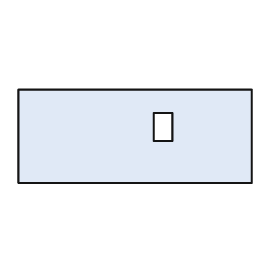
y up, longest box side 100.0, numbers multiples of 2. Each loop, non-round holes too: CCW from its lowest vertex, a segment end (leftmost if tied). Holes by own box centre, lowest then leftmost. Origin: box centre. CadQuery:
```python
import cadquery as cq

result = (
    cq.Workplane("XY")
    .moveTo(-50.0, -20.0)
    .lineTo(50.0, -20.0)
    .lineTo(50.0, 20.0)
    .lineTo(-50.0, 20.0)
    .close()
    .moveTo(8.0, -2.0)
    .lineTo(16.0, -2.0)
    .lineTo(16.0, 10.0)
    .lineTo(8.0, 10.0)
    .close()
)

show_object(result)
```